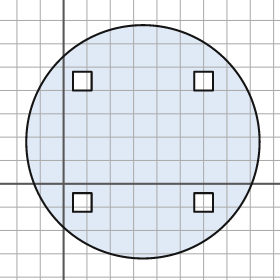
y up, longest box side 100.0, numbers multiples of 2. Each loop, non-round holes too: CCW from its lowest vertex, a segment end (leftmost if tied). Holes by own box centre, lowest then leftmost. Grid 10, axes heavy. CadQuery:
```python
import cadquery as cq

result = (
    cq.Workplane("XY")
    .moveTo(34.0, 18.0)
    .circle(50.0)
    .moveTo(4.0, -12.0)
    .lineTo(12.0, -12.0)
    .lineTo(12.0, -4.0)
    .lineTo(4.0, -4.0)
    .close()
    .moveTo(56.0, -12.0)
    .lineTo(64.0, -12.0)
    .lineTo(64.0, -4.0)
    .lineTo(56.0, -4.0)
    .close()
    .moveTo(4.0, 40.0)
    .lineTo(12.0, 40.0)
    .lineTo(12.0, 48.0)
    .lineTo(4.0, 48.0)
    .close()
    .moveTo(56.0, 40.0)
    .lineTo(64.0, 40.0)
    .lineTo(64.0, 48.0)
    .lineTo(56.0, 48.0)
    .close()
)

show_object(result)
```